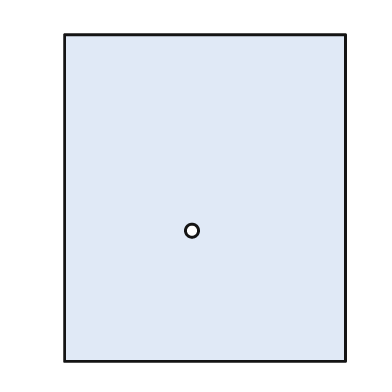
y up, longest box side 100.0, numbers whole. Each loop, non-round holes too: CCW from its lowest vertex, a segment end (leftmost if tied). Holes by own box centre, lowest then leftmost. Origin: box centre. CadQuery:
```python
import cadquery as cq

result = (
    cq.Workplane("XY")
    .moveTo(-43.0, -50.0)
    .lineTo(43.0, -50.0)
    .lineTo(43.0, 50.0)
    .lineTo(-43.0, 50.0)
    .close()
    .moveTo(-4.0, -10.0)
    .circle(2.0)
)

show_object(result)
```